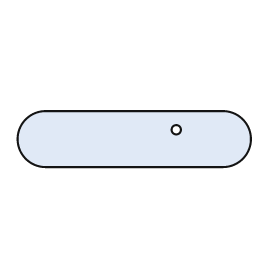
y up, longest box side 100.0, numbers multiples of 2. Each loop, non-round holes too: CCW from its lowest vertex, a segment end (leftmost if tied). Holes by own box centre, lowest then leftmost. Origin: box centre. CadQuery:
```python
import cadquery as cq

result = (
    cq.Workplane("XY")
    .moveTo(-38.0, -12.0)
    .lineTo(38.0, -12.0)
    .threePointArc((50.0, 0.0), (38.0, 12.0))
    .lineTo(-38.0, 12.0)
    .threePointArc((-50.0, 0.0), (-38.0, -12.0))
    .close()
    .moveTo(18.0, 4.0)
    .circle(2.0)
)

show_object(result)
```